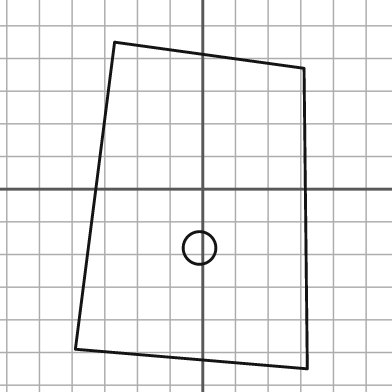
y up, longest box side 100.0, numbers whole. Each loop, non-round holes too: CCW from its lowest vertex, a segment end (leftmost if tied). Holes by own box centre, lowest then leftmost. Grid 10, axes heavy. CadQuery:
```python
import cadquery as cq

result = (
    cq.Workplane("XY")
    .moveTo(32.0, -55.0)
    .lineTo(31.0, 37.0)
    .lineTo(-27.0, 45.0)
    .lineTo(-39.0, -49.0)
    .close()
    .moveTo(-1.0, -18.0)
    .circle(5.0)
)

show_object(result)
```